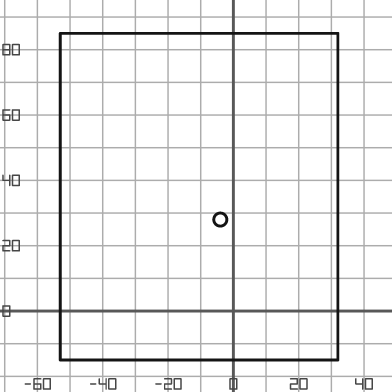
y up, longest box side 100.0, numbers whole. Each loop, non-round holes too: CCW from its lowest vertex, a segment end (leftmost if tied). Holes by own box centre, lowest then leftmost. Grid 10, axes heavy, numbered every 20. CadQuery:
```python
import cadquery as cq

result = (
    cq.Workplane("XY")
    .moveTo(-53.0, -15.0)
    .lineTo(32.0, -15.0)
    .lineTo(32.0, 85.0)
    .lineTo(-53.0, 85.0)
    .close()
    .moveTo(-4.0, 28.0)
    .circle(2.0)
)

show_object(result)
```